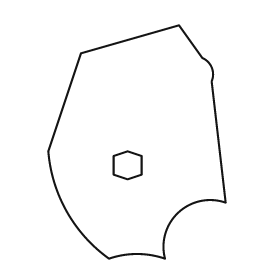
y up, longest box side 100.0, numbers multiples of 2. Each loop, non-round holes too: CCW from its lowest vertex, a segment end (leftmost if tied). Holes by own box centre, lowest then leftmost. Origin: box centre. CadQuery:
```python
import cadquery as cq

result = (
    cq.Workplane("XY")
    .moveTo(-12.0, -50.0)
    .threePointArc((0.0, -48.0), (12.0, -50.0))
    .threePointArc((18.0, -30.0), (38.0, -26.0))
    .lineTo(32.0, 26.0)
    .threePointArc((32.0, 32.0), (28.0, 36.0))
    .lineTo(18.0, 50.0)
    .lineTo(-24.0, 38.0)
    .lineTo(-38.0, -4.0)
    .threePointArc((-30.0, -30.0), (-12.0, -50.0))
    .close()
    .moveTo(-4.0, -16.0)
    .lineTo(2.0, -14.0)
    .lineTo(2.0, -6.0)
    .lineTo(-4.0, -4.0)
    .lineTo(-10.0, -6.0)
    .lineTo(-10.0, -14.0)
    .close()
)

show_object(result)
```